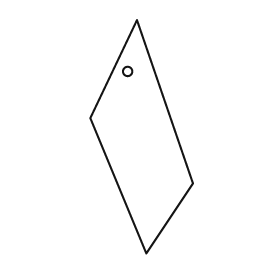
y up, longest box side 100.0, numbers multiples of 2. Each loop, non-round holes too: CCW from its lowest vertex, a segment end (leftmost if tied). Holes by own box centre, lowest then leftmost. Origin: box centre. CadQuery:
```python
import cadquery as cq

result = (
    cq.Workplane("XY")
    .moveTo(2.0, -50.0)
    .lineTo(22.0, -20.0)
    .lineTo(-2.0, 50.0)
    .lineTo(-22.0, 8.0)
    .close()
    .moveTo(-6.0, 28.0)
    .circle(2.0)
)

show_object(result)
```